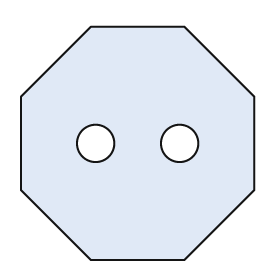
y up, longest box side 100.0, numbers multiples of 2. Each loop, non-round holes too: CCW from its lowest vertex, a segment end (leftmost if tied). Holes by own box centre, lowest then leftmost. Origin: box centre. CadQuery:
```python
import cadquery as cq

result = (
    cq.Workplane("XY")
    .moveTo(-20.0, -50.0)
    .lineTo(20.0, -50.0)
    .lineTo(50.0, -20.0)
    .lineTo(50.0, 20.0)
    .lineTo(20.0, 50.0)
    .lineTo(-20.0, 50.0)
    .lineTo(-50.0, 20.0)
    .lineTo(-50.0, -20.0)
    .close()
    .moveTo(-18.0, 0.0)
    .circle(8.0)
    .moveTo(18.0, 0.0)
    .circle(8.0)
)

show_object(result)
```